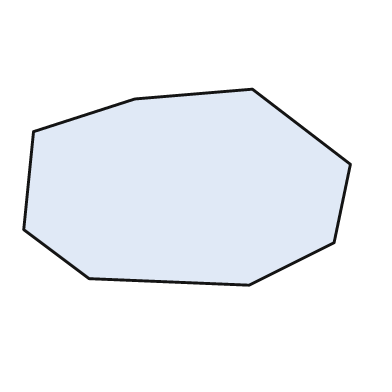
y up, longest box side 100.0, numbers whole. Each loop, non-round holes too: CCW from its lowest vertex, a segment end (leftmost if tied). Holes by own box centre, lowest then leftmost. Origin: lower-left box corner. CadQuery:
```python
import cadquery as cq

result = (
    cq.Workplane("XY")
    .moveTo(69.0, 0.0)
    .lineTo(95.0, 13.0)
    .lineTo(100.0, 37.0)
    .lineTo(70.0, 60.0)
    .lineTo(34.0, 57.0)
    .lineTo(3.0, 47.0)
    .lineTo(0.0, 17.0)
    .lineTo(20.0, 2.0)
    .close()
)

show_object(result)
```